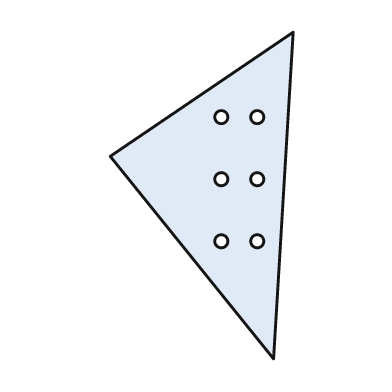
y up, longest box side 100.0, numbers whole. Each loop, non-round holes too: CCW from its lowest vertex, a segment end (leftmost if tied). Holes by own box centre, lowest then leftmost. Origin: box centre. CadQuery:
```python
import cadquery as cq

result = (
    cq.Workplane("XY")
    .moveTo(22.0, -50.0)
    .lineTo(28.0, 50.0)
    .lineTo(-28.0, 12.0)
    .close()
    .moveTo(6.0, -14.0)
    .circle(2.0)
    .moveTo(17.0, -14.0)
    .circle(2.0)
    .moveTo(6.0, 5.0)
    .circle(2.0)
    .moveTo(17.0, 5.0)
    .circle(2.0)
    .moveTo(6.0, 24.0)
    .circle(2.0)
    .moveTo(17.0, 24.0)
    .circle(2.0)
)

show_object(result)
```